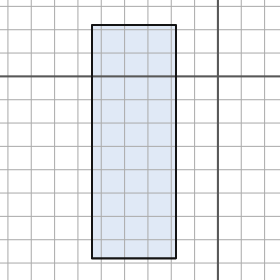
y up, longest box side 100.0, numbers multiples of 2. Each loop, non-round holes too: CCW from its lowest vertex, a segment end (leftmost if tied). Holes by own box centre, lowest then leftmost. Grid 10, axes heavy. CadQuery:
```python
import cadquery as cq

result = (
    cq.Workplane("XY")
    .moveTo(-54.0, -78.0)
    .lineTo(-18.0, -78.0)
    .lineTo(-18.0, 22.0)
    .lineTo(-54.0, 22.0)
    .close()
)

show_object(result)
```